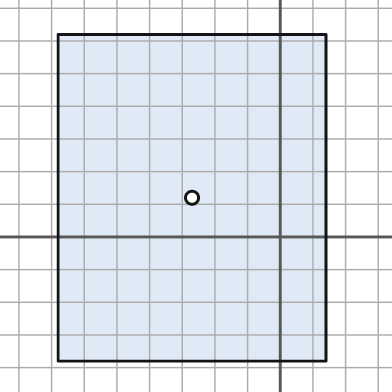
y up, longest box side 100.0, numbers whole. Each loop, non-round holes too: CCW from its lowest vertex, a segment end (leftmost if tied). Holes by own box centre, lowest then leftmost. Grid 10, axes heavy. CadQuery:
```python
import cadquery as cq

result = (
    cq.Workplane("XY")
    .moveTo(-68.0, -38.0)
    .lineTo(14.0, -38.0)
    .lineTo(14.0, 62.0)
    .lineTo(-68.0, 62.0)
    .close()
    .moveTo(-27.0, 12.0)
    .circle(2.0)
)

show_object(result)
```